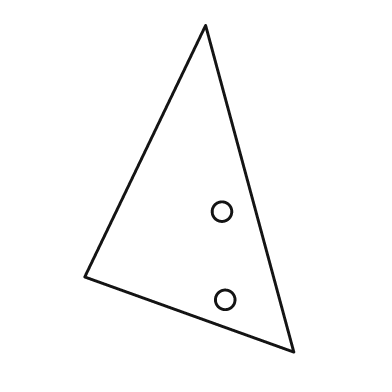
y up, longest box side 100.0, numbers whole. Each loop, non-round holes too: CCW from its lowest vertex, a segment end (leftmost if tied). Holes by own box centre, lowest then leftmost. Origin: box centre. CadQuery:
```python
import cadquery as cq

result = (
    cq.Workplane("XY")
    .moveTo(32.0, -50.0)
    .lineTo(5.0, 50.0)
    .lineTo(-32.0, -27.0)
    .close()
    .moveTo(11.0, -34.0)
    .circle(3.0)
    .moveTo(10.0, -7.0)
    .circle(3.0)
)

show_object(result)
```